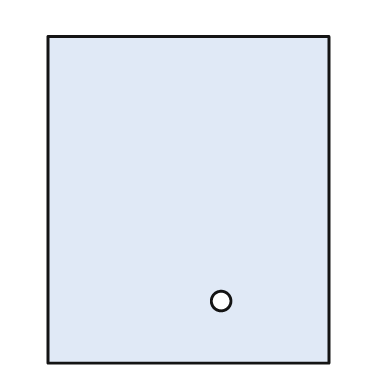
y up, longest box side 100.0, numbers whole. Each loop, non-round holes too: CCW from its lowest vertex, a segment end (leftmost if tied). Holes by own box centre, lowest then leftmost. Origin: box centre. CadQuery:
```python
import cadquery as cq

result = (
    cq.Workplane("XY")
    .moveTo(-43.0, -50.0)
    .lineTo(43.0, -50.0)
    .lineTo(43.0, 50.0)
    .lineTo(-43.0, 50.0)
    .close()
    .moveTo(10.0, -31.0)
    .circle(3.0)
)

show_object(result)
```